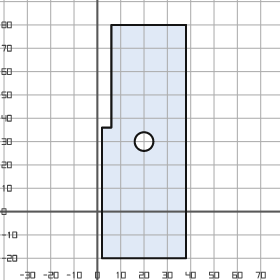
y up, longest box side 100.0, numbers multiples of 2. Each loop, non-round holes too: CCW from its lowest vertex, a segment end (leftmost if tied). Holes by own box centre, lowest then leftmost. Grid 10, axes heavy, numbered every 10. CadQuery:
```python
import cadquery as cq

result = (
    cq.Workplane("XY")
    .moveTo(2.0, -20.0)
    .lineTo(38.0, -20.0)
    .lineTo(38.0, 80.0)
    .lineTo(6.0, 80.0)
    .lineTo(6.0, 36.0)
    .lineTo(2.0, 36.0)
    .close()
    .moveTo(20.0, 30.0)
    .circle(4.0)
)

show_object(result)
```